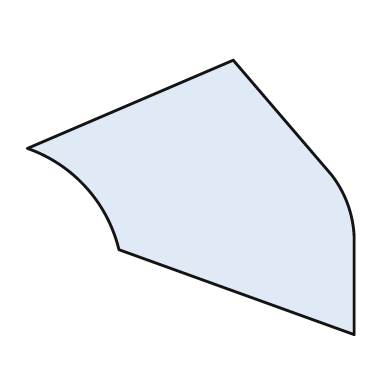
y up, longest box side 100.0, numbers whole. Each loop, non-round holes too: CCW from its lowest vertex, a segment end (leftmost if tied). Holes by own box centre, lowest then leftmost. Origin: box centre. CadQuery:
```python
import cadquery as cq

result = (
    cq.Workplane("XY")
    .moveTo(50.0, -42.0)
    .lineTo(50.0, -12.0)
    .threePointArc((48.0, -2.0), (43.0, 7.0))
    .lineTo(13.0, 42.0)
    .lineTo(-50.0, 15.0)
    .threePointArc((-32.0, 3.0), (-22.0, -16.0))
    .close()
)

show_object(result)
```